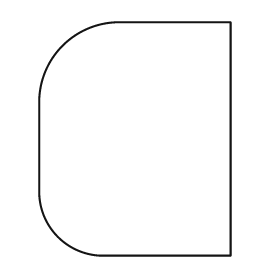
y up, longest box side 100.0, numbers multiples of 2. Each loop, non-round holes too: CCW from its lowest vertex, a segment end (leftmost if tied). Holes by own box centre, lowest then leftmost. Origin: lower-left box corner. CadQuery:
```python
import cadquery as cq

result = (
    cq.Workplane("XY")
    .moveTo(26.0, 0.0)
    .lineTo(82.0, 0.0)
    .lineTo(82.0, 100.0)
    .lineTo(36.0, 100.0)
    .threePointArc((10.0, 90.0), (0.0, 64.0))
    .lineTo(0.0, 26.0)
    .threePointArc((8.0, 8.0), (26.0, 0.0))
    .close()
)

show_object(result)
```